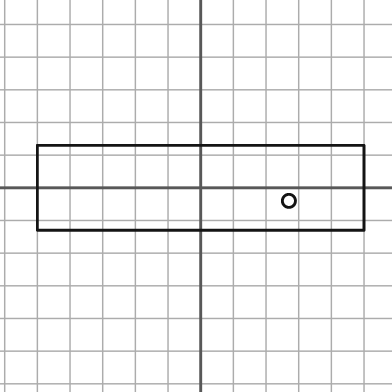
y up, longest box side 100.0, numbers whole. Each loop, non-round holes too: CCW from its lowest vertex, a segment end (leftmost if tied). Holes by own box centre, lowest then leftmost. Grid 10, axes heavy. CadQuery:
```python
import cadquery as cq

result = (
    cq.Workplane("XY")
    .moveTo(-50.0, -13.0)
    .lineTo(50.0, -13.0)
    .lineTo(50.0, 13.0)
    .lineTo(-50.0, 13.0)
    .close()
    .moveTo(27.0, -4.0)
    .circle(2.0)
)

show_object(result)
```